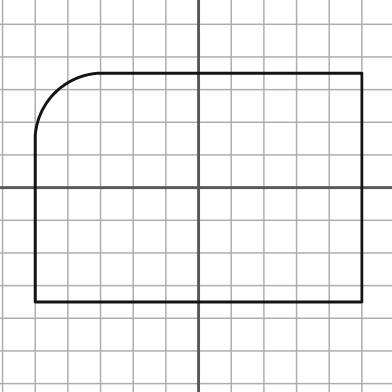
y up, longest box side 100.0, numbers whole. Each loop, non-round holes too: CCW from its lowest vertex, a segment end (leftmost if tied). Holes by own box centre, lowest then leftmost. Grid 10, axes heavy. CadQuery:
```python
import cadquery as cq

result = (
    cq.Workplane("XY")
    .moveTo(-50.0, -35.0)
    .lineTo(50.0, -35.0)
    .lineTo(50.0, 35.0)
    .lineTo(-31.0, 35.0)
    .threePointArc((-44.0, 29.0), (-50.0, 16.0))
    .close()
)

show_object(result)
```